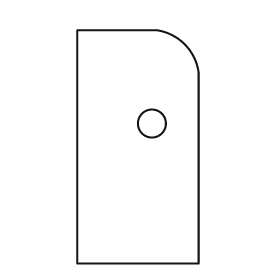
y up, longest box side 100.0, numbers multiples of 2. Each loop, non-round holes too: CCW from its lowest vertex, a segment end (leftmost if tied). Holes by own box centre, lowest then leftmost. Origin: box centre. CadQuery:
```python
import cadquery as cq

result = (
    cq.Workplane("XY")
    .moveTo(-26.0, -50.0)
    .lineTo(26.0, -50.0)
    .lineTo(26.0, 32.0)
    .threePointArc((20.0, 44.0), (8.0, 50.0))
    .lineTo(-26.0, 50.0)
    .close()
    .moveTo(6.0, 10.0)
    .circle(6.0)
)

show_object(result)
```